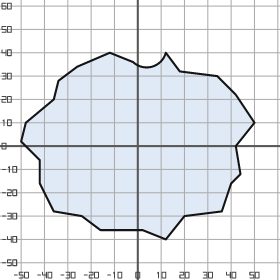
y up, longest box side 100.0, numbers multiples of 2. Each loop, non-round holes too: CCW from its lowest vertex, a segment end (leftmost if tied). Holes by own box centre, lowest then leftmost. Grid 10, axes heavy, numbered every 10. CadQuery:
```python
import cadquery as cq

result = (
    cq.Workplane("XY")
    .moveTo(12.0, -40.0)
    .lineTo(20.0, -30.0)
    .lineTo(36.0, -28.0)
    .lineTo(40.0, -16.0)
    .lineTo(44.0, -12.0)
    .lineTo(42.0, 0.0)
    .lineTo(50.0, 10.0)
    .lineTo(42.0, 22.0)
    .lineTo(34.0, 30.0)
    .lineTo(18.0, 32.0)
    .lineTo(12.0, 40.0)
    .threePointArc((6.0, 34.0), (-2.0, 36.0))
    .lineTo(-12.0, 40.0)
    .lineTo(-26.0, 34.0)
    .lineTo(-34.0, 28.0)
    .lineTo(-36.0, 20.0)
    .lineTo(-48.0, 10.0)
    .lineTo(-50.0, 2.0)
    .lineTo(-42.0, -6.0)
    .lineTo(-42.0, -16.0)
    .lineTo(-36.0, -28.0)
    .lineTo(-24.0, -30.0)
    .lineTo(-16.0, -36.0)
    .lineTo(2.0, -36.0)
    .close()
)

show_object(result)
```